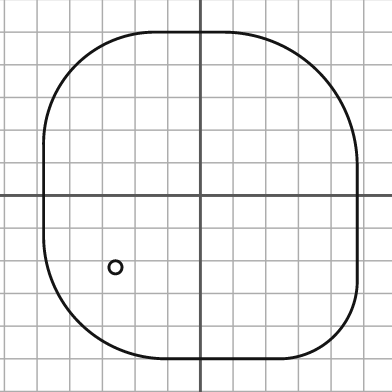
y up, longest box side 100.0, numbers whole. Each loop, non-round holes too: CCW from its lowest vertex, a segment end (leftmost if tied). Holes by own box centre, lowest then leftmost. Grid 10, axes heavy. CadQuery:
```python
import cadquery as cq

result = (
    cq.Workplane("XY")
    .moveTo(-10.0, -50.0)
    .lineTo(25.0, -50.0)
    .threePointArc((41.0, -43.0), (48.0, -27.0))
    .lineTo(48.0, 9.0)
    .threePointArc((36.0, 38.0), (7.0, 50.0))
    .lineTo(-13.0, 50.0)
    .threePointArc((-38.0, 40.0), (-48.0, 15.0))
    .lineTo(-48.0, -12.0)
    .threePointArc((-37.0, -39.0), (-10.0, -50.0))
    .close()
    .moveTo(-26.0, -22.0)
    .circle(2.0)
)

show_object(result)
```